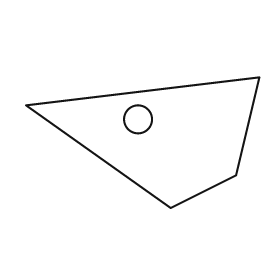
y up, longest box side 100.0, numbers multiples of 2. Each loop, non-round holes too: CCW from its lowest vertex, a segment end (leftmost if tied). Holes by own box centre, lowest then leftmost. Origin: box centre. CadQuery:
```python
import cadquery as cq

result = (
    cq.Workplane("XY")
    .moveTo(12.0, -28.0)
    .lineTo(40.0, -14.0)
    .lineTo(50.0, 28.0)
    .lineTo(-50.0, 16.0)
    .close()
    .moveTo(-2.0, 10.0)
    .circle(6.0)
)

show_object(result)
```